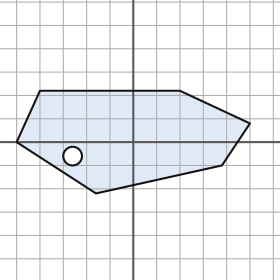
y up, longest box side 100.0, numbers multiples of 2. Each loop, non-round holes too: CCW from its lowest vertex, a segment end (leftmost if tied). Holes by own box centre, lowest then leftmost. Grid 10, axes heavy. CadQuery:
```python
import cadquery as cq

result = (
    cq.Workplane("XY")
    .moveTo(-16.0, -22.0)
    .lineTo(38.0, -10.0)
    .lineTo(50.0, 8.0)
    .lineTo(20.0, 22.0)
    .lineTo(-40.0, 22.0)
    .lineTo(-50.0, 0.0)
    .close()
    .moveTo(-26.0, -6.0)
    .circle(4.0)
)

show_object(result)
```